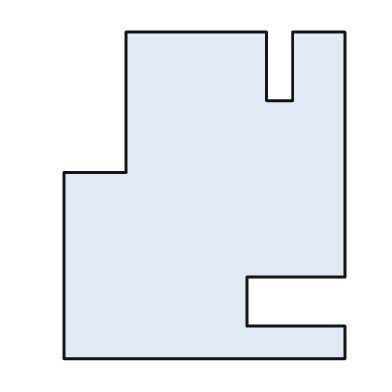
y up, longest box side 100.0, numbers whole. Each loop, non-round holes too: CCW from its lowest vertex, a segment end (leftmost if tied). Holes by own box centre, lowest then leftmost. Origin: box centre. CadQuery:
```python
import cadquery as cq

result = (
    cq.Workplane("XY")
    .moveTo(-43.0, -50.0)
    .lineTo(43.0, -50.0)
    .lineTo(43.0, -40.0)
    .lineTo(13.0, -40.0)
    .lineTo(13.0, -25.0)
    .lineTo(43.0, -25.0)
    .lineTo(43.0, 50.0)
    .lineTo(27.0, 50.0)
    .lineTo(27.0, 29.0)
    .lineTo(19.0, 29.0)
    .lineTo(19.0, 50.0)
    .lineTo(-24.0, 50.0)
    .lineTo(-24.0, 7.0)
    .lineTo(-43.0, 7.0)
    .close()
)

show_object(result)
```